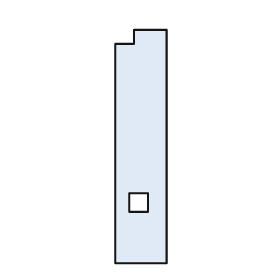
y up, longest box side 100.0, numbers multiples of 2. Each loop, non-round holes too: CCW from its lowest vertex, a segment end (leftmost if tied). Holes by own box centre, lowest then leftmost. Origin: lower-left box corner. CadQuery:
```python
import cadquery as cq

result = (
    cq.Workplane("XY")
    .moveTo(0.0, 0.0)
    .lineTo(22.0, 0.0)
    .lineTo(22.0, 100.0)
    .lineTo(8.0, 100.0)
    .lineTo(8.0, 94.0)
    .lineTo(0.0, 94.0)
    .close()
    .moveTo(6.0, 22.0)
    .lineTo(14.0, 22.0)
    .lineTo(14.0, 30.0)
    .lineTo(6.0, 30.0)
    .close()
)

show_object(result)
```